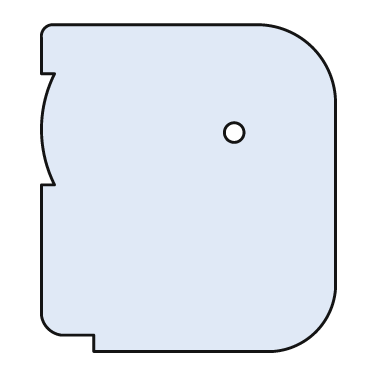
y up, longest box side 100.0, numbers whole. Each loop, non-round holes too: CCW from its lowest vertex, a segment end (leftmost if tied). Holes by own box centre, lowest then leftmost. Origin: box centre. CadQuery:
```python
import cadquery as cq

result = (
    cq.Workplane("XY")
    .moveTo(-29.0, -50.0)
    .lineTo(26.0, -50.0)
    .threePointArc((39.0, -44.0), (45.0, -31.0))
    .lineTo(45.0, 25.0)
    .threePointArc((38.0, 43.0), (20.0, 50.0))
    .lineTo(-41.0, 50.0)
    .threePointArc((-44.0, 49.0), (-45.0, 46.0))
    .lineTo(-45.0, 35.0)
    .lineTo(-41.0, 35.0)
    .threePointArc((-45.0, 18.0), (-41.0, 1.0))
    .lineTo(-45.0, 1.0)
    .lineTo(-45.0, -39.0)
    .threePointArc((-43.0, -43.0), (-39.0, -45.0))
    .lineTo(-29.0, -45.0)
    .close()
    .moveTo(14.0, 17.0)
    .circle(3.0)
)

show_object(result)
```